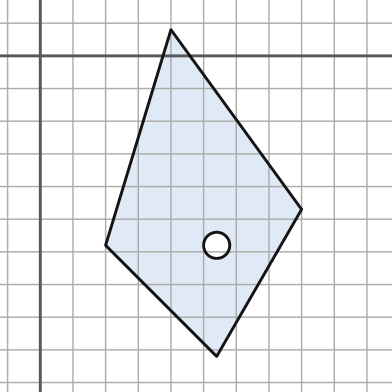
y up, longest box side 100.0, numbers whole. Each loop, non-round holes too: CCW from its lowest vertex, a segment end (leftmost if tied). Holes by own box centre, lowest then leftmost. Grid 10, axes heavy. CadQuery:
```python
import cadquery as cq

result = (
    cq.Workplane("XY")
    .moveTo(54.0, -92.0)
    .lineTo(80.0, -47.0)
    .lineTo(40.0, 8.0)
    .lineTo(20.0, -58.0)
    .close()
    .moveTo(54.0, -58.0)
    .circle(4.0)
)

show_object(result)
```